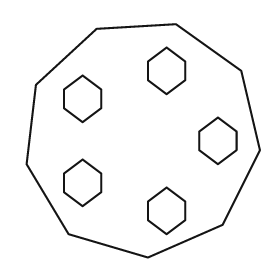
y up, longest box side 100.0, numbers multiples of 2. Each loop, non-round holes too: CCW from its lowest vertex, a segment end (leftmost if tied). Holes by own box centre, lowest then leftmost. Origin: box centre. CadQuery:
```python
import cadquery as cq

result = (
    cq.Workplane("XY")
    .moveTo(2.0, -50.0)
    .lineTo(34.0, -36.0)
    .lineTo(50.0, -4.0)
    .lineTo(42.0, 30.0)
    .lineTo(14.0, 50.0)
    .lineTo(-20.0, 48.0)
    .lineTo(-46.0, 24.0)
    .lineTo(-50.0, -10.0)
    .lineTo(-32.0, -40.0)
    .close()
    .moveTo(10.0, -40.0)
    .lineTo(18.0, -34.0)
    .lineTo(18.0, -26.0)
    .lineTo(10.0, -20.0)
    .lineTo(2.0, -26.0)
    .lineTo(2.0, -34.0)
    .close()
    .moveTo(-26.0, -28.0)
    .lineTo(-18.0, -22.0)
    .lineTo(-18.0, -14.0)
    .lineTo(-26.0, -8.0)
    .lineTo(-34.0, -14.0)
    .lineTo(-34.0, -22.0)
    .close()
    .moveTo(32.0, -10.0)
    .lineTo(40.0, -4.0)
    .lineTo(40.0, 4.0)
    .lineTo(32.0, 10.0)
    .lineTo(24.0, 4.0)
    .lineTo(24.0, -4.0)
    .close()
    .moveTo(-26.0, 8.0)
    .lineTo(-18.0, 14.0)
    .lineTo(-18.0, 22.0)
    .lineTo(-26.0, 28.0)
    .lineTo(-34.0, 22.0)
    .lineTo(-34.0, 14.0)
    .close()
    .moveTo(10.0, 20.0)
    .lineTo(18.0, 26.0)
    .lineTo(18.0, 34.0)
    .lineTo(10.0, 40.0)
    .lineTo(2.0, 34.0)
    .lineTo(2.0, 26.0)
    .close()
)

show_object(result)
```